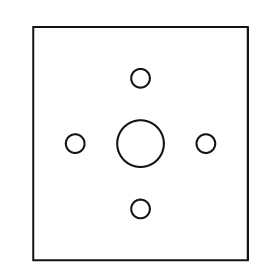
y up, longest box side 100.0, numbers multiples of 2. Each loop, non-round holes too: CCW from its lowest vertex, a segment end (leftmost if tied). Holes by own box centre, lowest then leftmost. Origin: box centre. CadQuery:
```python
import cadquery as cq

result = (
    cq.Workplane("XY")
    .moveTo(-46.0, -50.0)
    .lineTo(46.0, -50.0)
    .lineTo(46.0, 50.0)
    .lineTo(-46.0, 50.0)
    .close()
    .moveTo(0.0, -28.0)
    .circle(4.0)
    .moveTo(-28.0, 0.0)
    .circle(4.0)
    .moveTo(0.0, 0.0)
    .circle(10.0)
    .moveTo(28.0, 0.0)
    .circle(4.0)
    .moveTo(0.0, 28.0)
    .circle(4.0)
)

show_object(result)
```